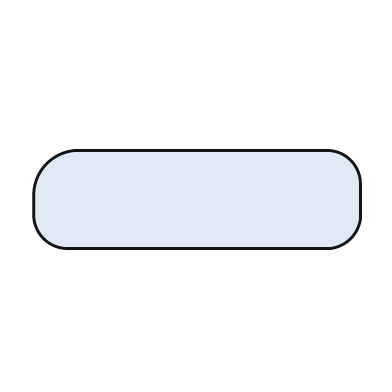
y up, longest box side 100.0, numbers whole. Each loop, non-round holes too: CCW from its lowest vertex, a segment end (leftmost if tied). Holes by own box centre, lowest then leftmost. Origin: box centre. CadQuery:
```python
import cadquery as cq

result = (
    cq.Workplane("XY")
    .moveTo(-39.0, -15.0)
    .lineTo(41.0, -15.0)
    .threePointArc((47.0, -12.0), (50.0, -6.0))
    .lineTo(50.0, 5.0)
    .threePointArc((47.0, 12.0), (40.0, 15.0))
    .lineTo(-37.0, 15.0)
    .threePointArc((-46.0, 11.0), (-50.0, 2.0))
    .lineTo(-50.0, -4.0)
    .threePointArc((-47.0, -12.0), (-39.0, -15.0))
    .close()
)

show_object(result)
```